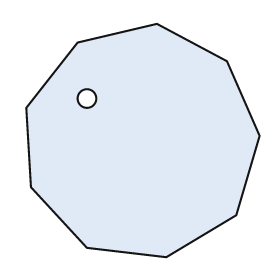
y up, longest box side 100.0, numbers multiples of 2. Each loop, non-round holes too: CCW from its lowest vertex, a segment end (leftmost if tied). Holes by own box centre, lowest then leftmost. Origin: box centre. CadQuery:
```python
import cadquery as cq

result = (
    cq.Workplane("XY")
    .moveTo(10.0, -50.0)
    .lineTo(40.0, -32.0)
    .lineTo(50.0, 2.0)
    .lineTo(36.0, 34.0)
    .lineTo(6.0, 50.0)
    .lineTo(-28.0, 42.0)
    .lineTo(-50.0, 14.0)
    .lineTo(-48.0, -20.0)
    .lineTo(-24.0, -46.0)
    .close()
    .moveTo(-24.0, 18.0)
    .circle(4.0)
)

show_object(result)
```